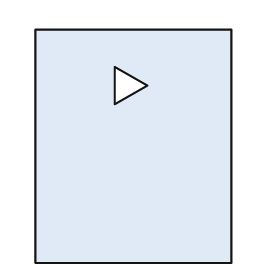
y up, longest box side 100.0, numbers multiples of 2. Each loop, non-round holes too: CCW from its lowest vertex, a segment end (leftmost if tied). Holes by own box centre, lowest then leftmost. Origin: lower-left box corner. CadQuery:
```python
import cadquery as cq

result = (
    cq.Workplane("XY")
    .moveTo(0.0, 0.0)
    .lineTo(84.0, 0.0)
    .lineTo(84.0, 100.0)
    .lineTo(0.0, 100.0)
    .close()
    .moveTo(34.0, 68.0)
    .lineTo(48.0, 76.0)
    .lineTo(34.0, 84.0)
    .close()
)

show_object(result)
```